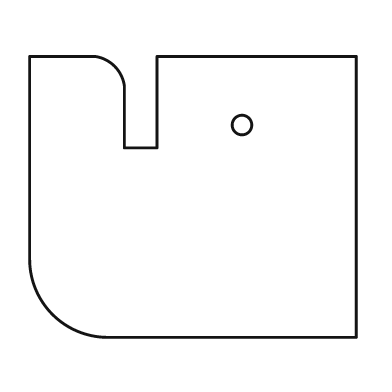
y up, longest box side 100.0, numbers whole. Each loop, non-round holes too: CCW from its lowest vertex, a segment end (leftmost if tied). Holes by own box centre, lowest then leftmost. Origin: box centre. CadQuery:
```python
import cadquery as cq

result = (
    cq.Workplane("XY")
    .moveTo(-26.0, -43.0)
    .lineTo(50.0, -43.0)
    .lineTo(50.0, 43.0)
    .lineTo(-11.0, 43.0)
    .lineTo(-11.0, 15.0)
    .lineTo(-21.0, 15.0)
    .lineTo(-21.0, 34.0)
    .threePointArc((-24.0, 40.0), (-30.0, 43.0))
    .lineTo(-50.0, 43.0)
    .lineTo(-50.0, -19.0)
    .threePointArc((-43.0, -36.0), (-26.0, -43.0))
    .close()
    .moveTo(15.0, 22.0)
    .circle(3.0)
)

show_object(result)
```